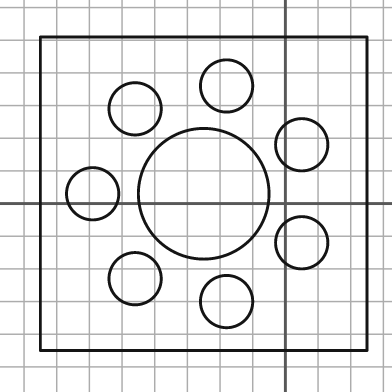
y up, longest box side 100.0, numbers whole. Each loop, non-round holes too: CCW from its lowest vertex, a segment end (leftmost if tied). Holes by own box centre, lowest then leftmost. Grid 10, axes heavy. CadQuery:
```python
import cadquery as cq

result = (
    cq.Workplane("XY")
    .moveTo(-75.0, -45.0)
    .lineTo(25.0, -45.0)
    .lineTo(25.0, 51.0)
    .lineTo(-75.0, 51.0)
    .close()
    .moveTo(-18.0, -30.0)
    .circle(8.0)
    .moveTo(-46.0, -23.0)
    .circle(8.0)
    .moveTo(5.0, -12.0)
    .circle(8.0)
    .moveTo(-59.0, 3.0)
    .circle(8.0)
    .moveTo(-25.0, 3.0)
    .circle(20.0)
    .moveTo(5.0, 18.0)
    .circle(8.0)
    .moveTo(-46.0, 29.0)
    .circle(8.0)
    .moveTo(-18.0, 36.0)
    .circle(8.0)
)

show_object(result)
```